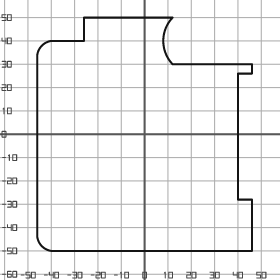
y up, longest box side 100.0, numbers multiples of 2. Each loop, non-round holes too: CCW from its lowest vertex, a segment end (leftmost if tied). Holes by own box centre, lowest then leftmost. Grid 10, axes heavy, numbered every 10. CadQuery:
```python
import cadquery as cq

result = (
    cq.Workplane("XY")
    .moveTo(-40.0, -50.0)
    .lineTo(46.0, -50.0)
    .lineTo(46.0, -28.0)
    .lineTo(40.0, -28.0)
    .lineTo(40.0, 26.0)
    .lineTo(46.0, 26.0)
    .lineTo(46.0, 30.0)
    .lineTo(12.0, 30.0)
    .threePointArc((8.0, 40.0), (12.0, 50.0))
    .lineTo(-26.0, 50.0)
    .lineTo(-26.0, 40.0)
    .lineTo(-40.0, 40.0)
    .threePointArc((-44.0, 38.0), (-46.0, 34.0))
    .lineTo(-46.0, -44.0)
    .threePointArc((-44.0, -48.0), (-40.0, -50.0))
    .close()
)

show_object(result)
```